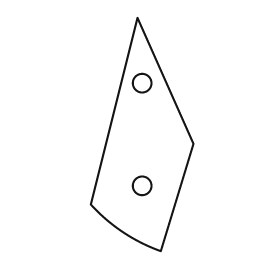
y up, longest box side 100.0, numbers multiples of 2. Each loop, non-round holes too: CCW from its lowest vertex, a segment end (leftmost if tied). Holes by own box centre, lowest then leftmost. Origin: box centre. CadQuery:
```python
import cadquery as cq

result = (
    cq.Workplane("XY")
    .moveTo(8.0, -50.0)
    .lineTo(22.0, -4.0)
    .lineTo(-2.0, 50.0)
    .lineTo(-22.0, -30.0)
    .threePointArc((-8.0, -42.0), (8.0, -50.0))
    .close()
    .moveTo(0.0, -22.0)
    .circle(4.0)
    .moveTo(0.0, 22.0)
    .circle(4.0)
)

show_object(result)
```